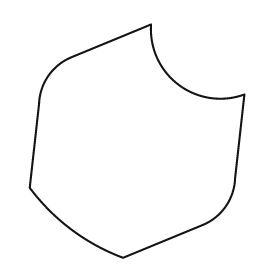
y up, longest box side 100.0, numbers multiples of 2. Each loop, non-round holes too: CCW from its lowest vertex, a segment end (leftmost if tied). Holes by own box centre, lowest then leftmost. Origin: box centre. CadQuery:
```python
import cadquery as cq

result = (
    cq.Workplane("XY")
    .moveTo(-6.0, -50.0)
    .lineTo(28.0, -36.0)
    .threePointArc((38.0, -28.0), (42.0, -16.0))
    .lineTo(46.0, 20.0)
    .threePointArc((18.0, 24.0), (6.0, 50.0))
    .lineTo(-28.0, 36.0)
    .threePointArc((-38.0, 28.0), (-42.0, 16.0))
    .lineTo(-46.0, -20.0)
    .threePointArc((-28.0, -38.0), (-6.0, -50.0))
    .close()
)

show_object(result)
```